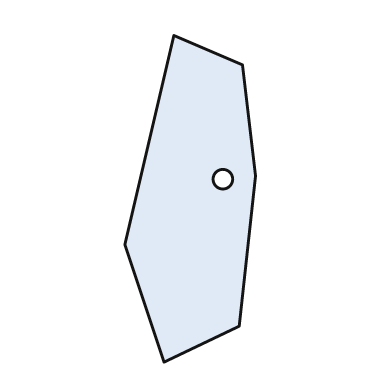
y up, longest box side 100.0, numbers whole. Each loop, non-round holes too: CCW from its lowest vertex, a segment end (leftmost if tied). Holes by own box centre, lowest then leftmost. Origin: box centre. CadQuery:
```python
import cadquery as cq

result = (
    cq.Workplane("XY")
    .moveTo(-8.0, -50.0)
    .lineTo(15.0, -39.0)
    .lineTo(20.0, 7.0)
    .lineTo(16.0, 41.0)
    .lineTo(-5.0, 50.0)
    .lineTo(-20.0, -14.0)
    .close()
    .moveTo(10.0, 6.0)
    .circle(3.0)
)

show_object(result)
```